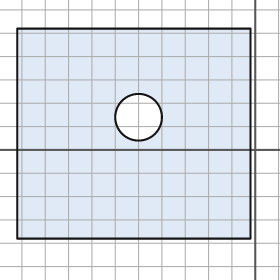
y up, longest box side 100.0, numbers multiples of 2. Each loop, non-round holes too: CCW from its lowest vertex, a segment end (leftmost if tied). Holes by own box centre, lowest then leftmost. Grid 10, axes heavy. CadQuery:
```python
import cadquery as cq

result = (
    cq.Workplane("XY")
    .moveTo(-102.0, -38.0)
    .lineTo(-2.0, -38.0)
    .lineTo(-2.0, 52.0)
    .lineTo(-102.0, 52.0)
    .close()
    .moveTo(-50.0, 14.0)
    .circle(10.0)
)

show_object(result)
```